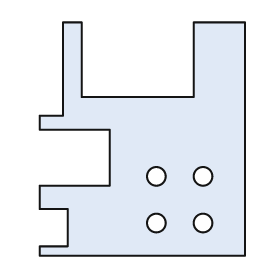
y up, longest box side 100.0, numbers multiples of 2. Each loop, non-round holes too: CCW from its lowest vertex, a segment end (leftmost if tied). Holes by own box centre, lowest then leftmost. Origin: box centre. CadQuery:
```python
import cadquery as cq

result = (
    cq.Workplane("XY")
    .moveTo(-44.0, -50.0)
    .lineTo(44.0, -50.0)
    .lineTo(44.0, 50.0)
    .lineTo(22.0, 50.0)
    .lineTo(22.0, 18.0)
    .lineTo(-26.0, 18.0)
    .lineTo(-26.0, 50.0)
    .lineTo(-34.0, 50.0)
    .lineTo(-34.0, 10.0)
    .lineTo(-44.0, 10.0)
    .lineTo(-44.0, 4.0)
    .lineTo(-14.0, 4.0)
    .lineTo(-14.0, -20.0)
    .lineTo(-44.0, -20.0)
    .lineTo(-44.0, -30.0)
    .lineTo(-32.0, -30.0)
    .lineTo(-32.0, -46.0)
    .lineTo(-44.0, -46.0)
    .close()
    .moveTo(6.0, -36.0)
    .circle(4.0)
    .moveTo(26.0, -36.0)
    .circle(4.0)
    .moveTo(6.0, -16.0)
    .circle(4.0)
    .moveTo(26.0, -16.0)
    .circle(4.0)
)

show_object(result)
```